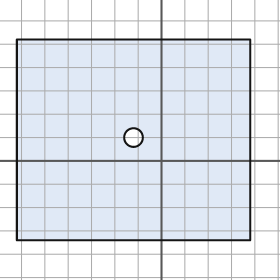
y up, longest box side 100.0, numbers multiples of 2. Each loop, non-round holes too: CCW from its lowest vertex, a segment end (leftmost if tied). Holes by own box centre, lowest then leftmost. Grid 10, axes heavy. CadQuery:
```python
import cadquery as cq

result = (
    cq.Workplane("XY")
    .moveTo(-62.0, -34.0)
    .lineTo(38.0, -34.0)
    .lineTo(38.0, 52.0)
    .lineTo(-62.0, 52.0)
    .close()
    .moveTo(-12.0, 10.0)
    .circle(4.0)
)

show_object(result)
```